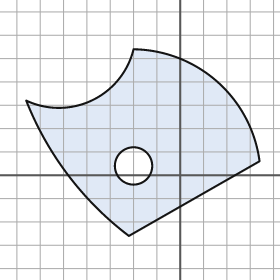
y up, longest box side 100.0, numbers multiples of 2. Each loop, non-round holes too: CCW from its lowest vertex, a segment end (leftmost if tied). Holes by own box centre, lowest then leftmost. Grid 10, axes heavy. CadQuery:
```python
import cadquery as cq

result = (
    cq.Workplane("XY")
    .moveTo(-22.0, -26.0)
    .lineTo(34.0, 6.0)
    .threePointArc((16.0, 40.0), (-20.0, 54.0))
    .threePointArc((-38.0, 32.0), (-66.0, 32.0))
    .threePointArc((-48.0, 0.0), (-22.0, -26.0))
    .close()
    .moveTo(-20.0, 4.0)
    .circle(8.0)
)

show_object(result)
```